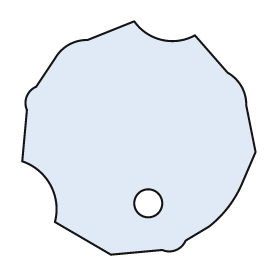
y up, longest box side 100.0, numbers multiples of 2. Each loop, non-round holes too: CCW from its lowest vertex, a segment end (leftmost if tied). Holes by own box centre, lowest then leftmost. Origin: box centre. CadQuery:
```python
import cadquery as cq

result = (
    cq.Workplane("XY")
    .moveTo(-12.0, -50.0)
    .lineTo(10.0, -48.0)
    .threePointArc((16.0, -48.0), (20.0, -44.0))
    .lineTo(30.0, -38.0)
    .threePointArc((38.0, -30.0), (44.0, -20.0))
    .lineTo(50.0, -6.0)
    .lineTo(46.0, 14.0)
    .threePointArc((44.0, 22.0), (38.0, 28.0))
    .lineTo(24.0, 44.0)
    .threePointArc((10.0, 42.0), (-2.0, 50.0))
    .lineTo(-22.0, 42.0)
    .threePointArc((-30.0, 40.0), (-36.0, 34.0))
    .lineTo(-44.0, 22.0)
    .threePointArc((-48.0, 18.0), (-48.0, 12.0))
    .lineTo(-50.0, -10.0)
    .threePointArc((-38.0, -20.0), (-36.0, -36.0))
    .close()
    .moveTo(4.0, -28.0)
    .circle(6.0)
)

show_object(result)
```